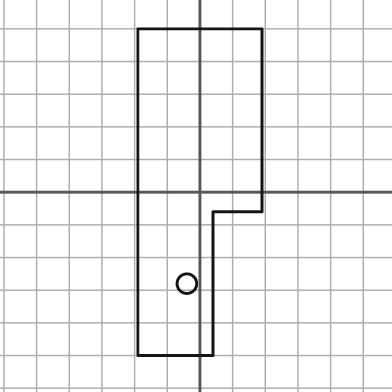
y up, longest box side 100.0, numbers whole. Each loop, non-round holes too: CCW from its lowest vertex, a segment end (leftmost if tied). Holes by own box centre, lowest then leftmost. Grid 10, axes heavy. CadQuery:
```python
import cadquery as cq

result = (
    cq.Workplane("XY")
    .moveTo(-19.0, -50.0)
    .lineTo(4.0, -50.0)
    .lineTo(4.0, -6.0)
    .lineTo(19.0, -6.0)
    .lineTo(19.0, 50.0)
    .lineTo(-19.0, 50.0)
    .close()
    .moveTo(-4.0, -28.0)
    .circle(3.0)
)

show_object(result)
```